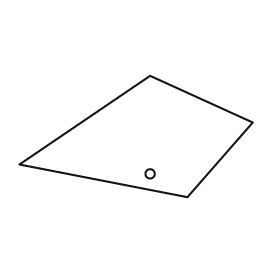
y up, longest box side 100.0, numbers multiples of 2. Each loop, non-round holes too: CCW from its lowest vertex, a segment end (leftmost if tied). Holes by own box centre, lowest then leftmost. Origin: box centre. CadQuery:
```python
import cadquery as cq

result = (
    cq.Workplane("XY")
    .moveTo(22.0, -26.0)
    .lineTo(50.0, 6.0)
    .lineTo(6.0, 26.0)
    .lineTo(-50.0, -12.0)
    .close()
    .moveTo(6.0, -16.0)
    .circle(2.0)
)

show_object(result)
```